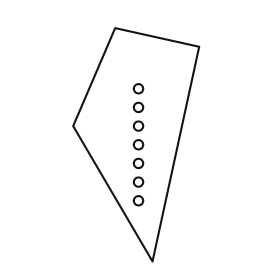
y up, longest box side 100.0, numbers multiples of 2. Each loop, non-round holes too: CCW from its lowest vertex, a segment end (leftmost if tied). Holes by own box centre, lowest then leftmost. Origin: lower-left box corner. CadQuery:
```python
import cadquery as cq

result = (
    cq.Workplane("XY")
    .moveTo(34.0, 0.0)
    .lineTo(54.0, 92.0)
    .lineTo(18.0, 100.0)
    .lineTo(0.0, 58.0)
    .close()
    .moveTo(28.0, 26.0)
    .circle(2.0)
    .moveTo(28.0, 34.0)
    .circle(2.0)
    .moveTo(28.0, 42.0)
    .circle(2.0)
    .moveTo(28.0, 50.0)
    .circle(2.0)
    .moveTo(28.0, 58.0)
    .circle(2.0)
    .moveTo(28.0, 66.0)
    .circle(2.0)
    .moveTo(28.0, 74.0)
    .circle(2.0)
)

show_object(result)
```